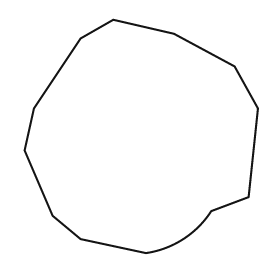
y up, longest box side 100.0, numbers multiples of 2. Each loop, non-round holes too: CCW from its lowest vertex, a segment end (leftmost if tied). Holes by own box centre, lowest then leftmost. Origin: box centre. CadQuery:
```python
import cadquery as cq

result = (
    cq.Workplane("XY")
    .moveTo(2.0, -50.0)
    .threePointArc((18.0, -44.0), (30.0, -32.0))
    .lineTo(46.0, -26.0)
    .lineTo(50.0, 12.0)
    .lineTo(40.0, 30.0)
    .lineTo(14.0, 44.0)
    .lineTo(-12.0, 50.0)
    .lineTo(-26.0, 42.0)
    .lineTo(-46.0, 12.0)
    .lineTo(-50.0, -6.0)
    .lineTo(-38.0, -34.0)
    .lineTo(-26.0, -44.0)
    .close()
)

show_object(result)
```